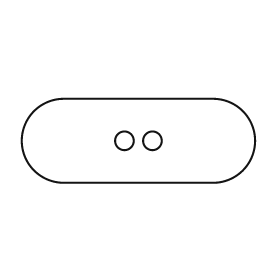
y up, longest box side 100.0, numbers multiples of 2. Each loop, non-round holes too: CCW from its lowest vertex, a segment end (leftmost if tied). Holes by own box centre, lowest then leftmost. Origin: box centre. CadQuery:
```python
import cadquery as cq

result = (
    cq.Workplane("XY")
    .moveTo(-32.0, -18.0)
    .lineTo(32.0, -18.0)
    .threePointArc((50.0, 0.0), (32.0, 18.0))
    .lineTo(-32.0, 18.0)
    .threePointArc((-50.0, 0.0), (-32.0, -18.0))
    .close()
    .moveTo(-6.0, 0.0)
    .circle(4.0)
    .moveTo(6.0, 0.0)
    .circle(4.0)
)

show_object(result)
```